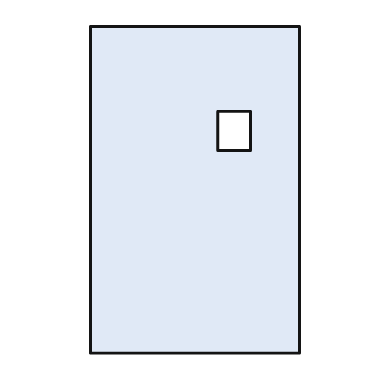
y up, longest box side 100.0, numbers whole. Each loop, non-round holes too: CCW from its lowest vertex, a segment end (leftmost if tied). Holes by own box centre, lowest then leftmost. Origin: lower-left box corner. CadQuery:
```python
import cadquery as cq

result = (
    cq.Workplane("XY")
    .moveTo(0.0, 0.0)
    .lineTo(64.0, 0.0)
    .lineTo(64.0, 100.0)
    .lineTo(0.0, 100.0)
    .close()
    .moveTo(39.0, 62.0)
    .lineTo(49.0, 62.0)
    .lineTo(49.0, 74.0)
    .lineTo(39.0, 74.0)
    .close()
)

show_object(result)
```